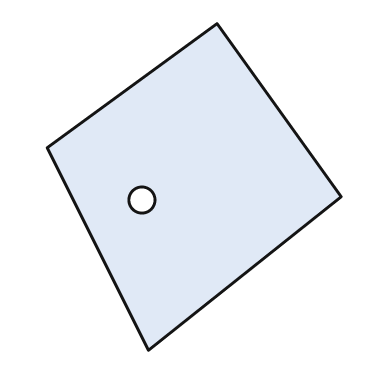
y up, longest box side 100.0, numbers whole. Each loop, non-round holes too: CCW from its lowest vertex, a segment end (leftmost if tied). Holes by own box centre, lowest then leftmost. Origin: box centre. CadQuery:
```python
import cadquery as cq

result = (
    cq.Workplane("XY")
    .moveTo(-14.0, -50.0)
    .lineTo(45.0, -3.0)
    .lineTo(7.0, 50.0)
    .lineTo(-45.0, 12.0)
    .close()
    .moveTo(-16.0, -4.0)
    .circle(4.0)
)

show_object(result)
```